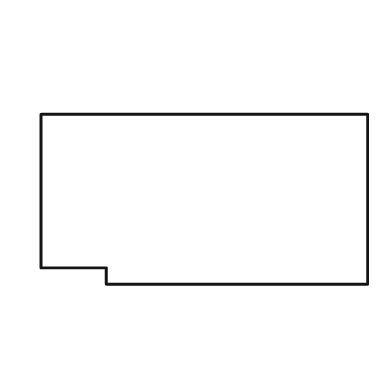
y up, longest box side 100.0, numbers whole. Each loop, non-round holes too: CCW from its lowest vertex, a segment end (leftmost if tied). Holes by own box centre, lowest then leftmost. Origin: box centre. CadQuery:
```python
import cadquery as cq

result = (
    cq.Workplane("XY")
    .moveTo(-30.0, -26.0)
    .lineTo(50.0, -26.0)
    .lineTo(50.0, 26.0)
    .lineTo(-50.0, 26.0)
    .lineTo(-50.0, -21.0)
    .lineTo(-30.0, -21.0)
    .close()
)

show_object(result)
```